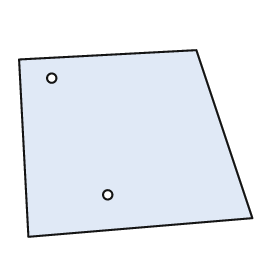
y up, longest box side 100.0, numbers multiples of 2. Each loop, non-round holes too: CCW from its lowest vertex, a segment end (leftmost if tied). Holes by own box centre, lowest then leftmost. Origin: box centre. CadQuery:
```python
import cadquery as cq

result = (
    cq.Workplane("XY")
    .moveTo(-46.0, -40.0)
    .lineTo(50.0, -32.0)
    .lineTo(26.0, 40.0)
    .lineTo(-50.0, 36.0)
    .close()
    .moveTo(-12.0, -22.0)
    .circle(2.0)
    .moveTo(-36.0, 28.0)
    .circle(2.0)
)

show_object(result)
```